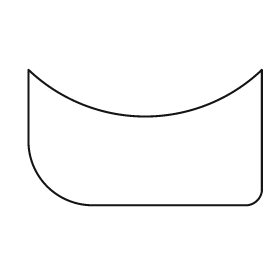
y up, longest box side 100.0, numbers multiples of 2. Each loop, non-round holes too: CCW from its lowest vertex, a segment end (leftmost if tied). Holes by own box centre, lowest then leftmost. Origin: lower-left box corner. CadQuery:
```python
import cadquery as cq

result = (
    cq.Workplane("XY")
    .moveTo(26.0, 0.0)
    .lineTo(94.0, 0.0)
    .threePointArc((98.0, 2.0), (100.0, 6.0))
    .lineTo(100.0, 58.0)
    .threePointArc((50.0, 38.0), (0.0, 58.0))
    .lineTo(0.0, 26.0)
    .threePointArc((8.0, 8.0), (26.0, 0.0))
    .close()
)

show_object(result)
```